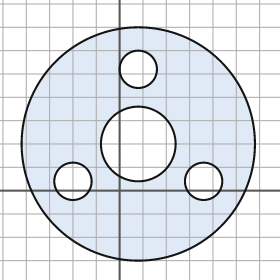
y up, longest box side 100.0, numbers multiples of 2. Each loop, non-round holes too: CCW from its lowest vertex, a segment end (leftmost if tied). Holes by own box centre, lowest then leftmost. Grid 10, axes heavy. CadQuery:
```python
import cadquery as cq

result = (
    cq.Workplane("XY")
    .moveTo(8.0, 20.0)
    .circle(50.0)
    .moveTo(-20.0, 4.0)
    .circle(8.0)
    .moveTo(36.0, 4.0)
    .circle(8.0)
    .moveTo(8.0, 20.0)
    .circle(16.0)
    .moveTo(8.0, 52.0)
    .circle(8.0)
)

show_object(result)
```